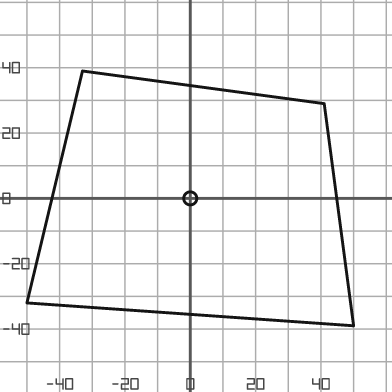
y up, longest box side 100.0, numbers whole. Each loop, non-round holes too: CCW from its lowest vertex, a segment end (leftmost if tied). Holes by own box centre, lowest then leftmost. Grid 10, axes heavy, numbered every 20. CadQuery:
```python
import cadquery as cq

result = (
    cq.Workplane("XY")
    .moveTo(50.0, -39.0)
    .lineTo(41.0, 29.0)
    .lineTo(-33.0, 39.0)
    .lineTo(-50.0, -32.0)
    .close()
    .moveTo(0.0, 0.0)
    .circle(2.0)
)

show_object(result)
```